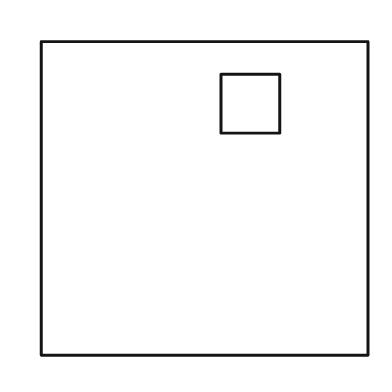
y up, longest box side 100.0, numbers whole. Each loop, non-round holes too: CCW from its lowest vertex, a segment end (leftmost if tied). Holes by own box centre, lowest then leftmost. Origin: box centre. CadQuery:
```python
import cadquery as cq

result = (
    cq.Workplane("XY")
    .moveTo(-50.0, -48.0)
    .lineTo(50.0, -48.0)
    .lineTo(50.0, 48.0)
    .lineTo(-50.0, 48.0)
    .close()
    .moveTo(5.0, 20.0)
    .lineTo(23.0, 20.0)
    .lineTo(23.0, 38.0)
    .lineTo(5.0, 38.0)
    .close()
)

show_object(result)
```